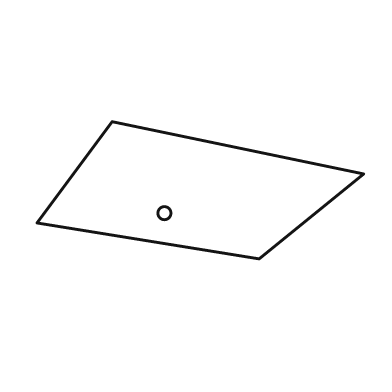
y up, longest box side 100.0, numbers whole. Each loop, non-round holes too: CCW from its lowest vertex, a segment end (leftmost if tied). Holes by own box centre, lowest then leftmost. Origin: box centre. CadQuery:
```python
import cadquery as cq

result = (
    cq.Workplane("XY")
    .moveTo(18.0, -21.0)
    .lineTo(50.0, 5.0)
    .lineTo(-27.0, 21.0)
    .lineTo(-50.0, -10.0)
    .close()
    .moveTo(-11.0, -7.0)
    .circle(2.0)
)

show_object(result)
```